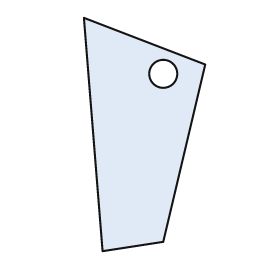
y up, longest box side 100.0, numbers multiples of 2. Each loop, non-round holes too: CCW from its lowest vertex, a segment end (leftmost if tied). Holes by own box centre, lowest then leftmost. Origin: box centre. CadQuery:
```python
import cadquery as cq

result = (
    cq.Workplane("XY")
    .moveTo(-18.0, -50.0)
    .lineTo(8.0, -46.0)
    .lineTo(26.0, 30.0)
    .lineTo(-26.0, 50.0)
    .close()
    .moveTo(8.0, 26.0)
    .circle(6.0)
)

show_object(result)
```